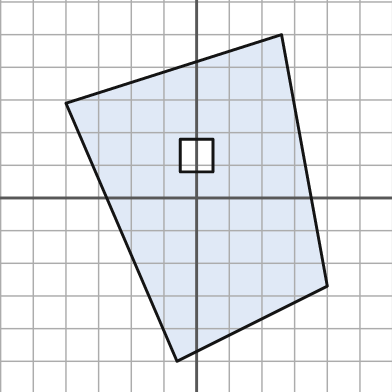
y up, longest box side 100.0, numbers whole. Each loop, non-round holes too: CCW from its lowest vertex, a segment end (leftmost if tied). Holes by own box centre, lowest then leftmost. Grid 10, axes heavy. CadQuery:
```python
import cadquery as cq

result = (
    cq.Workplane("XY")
    .moveTo(-6.0, -50.0)
    .lineTo(40.0, -27.0)
    .lineTo(26.0, 50.0)
    .lineTo(-40.0, 29.0)
    .close()
    .moveTo(-5.0, 8.0)
    .lineTo(5.0, 8.0)
    .lineTo(5.0, 18.0)
    .lineTo(-5.0, 18.0)
    .close()
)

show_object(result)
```